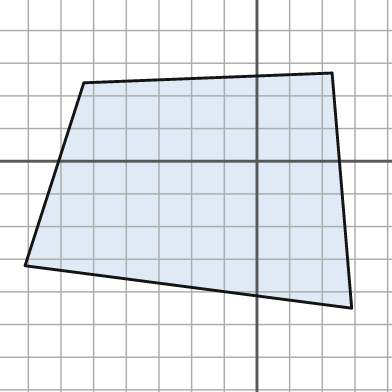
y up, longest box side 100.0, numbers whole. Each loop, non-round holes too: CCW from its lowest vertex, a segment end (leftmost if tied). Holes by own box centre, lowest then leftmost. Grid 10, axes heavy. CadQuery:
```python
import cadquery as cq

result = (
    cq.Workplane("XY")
    .moveTo(29.0, -45.0)
    .lineTo(23.0, 27.0)
    .lineTo(-53.0, 24.0)
    .lineTo(-71.0, -32.0)
    .close()
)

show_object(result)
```